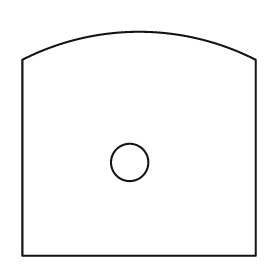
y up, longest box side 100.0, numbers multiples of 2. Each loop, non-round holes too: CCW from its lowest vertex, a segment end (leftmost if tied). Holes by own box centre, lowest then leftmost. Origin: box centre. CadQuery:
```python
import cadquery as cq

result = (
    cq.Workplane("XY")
    .moveTo(-50.0, -48.0)
    .lineTo(50.0, -48.0)
    .lineTo(50.0, 36.0)
    .threePointArc((0.0, 48.0), (-50.0, 36.0))
    .close()
    .moveTo(-4.0, -8.0)
    .circle(8.0)
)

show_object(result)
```